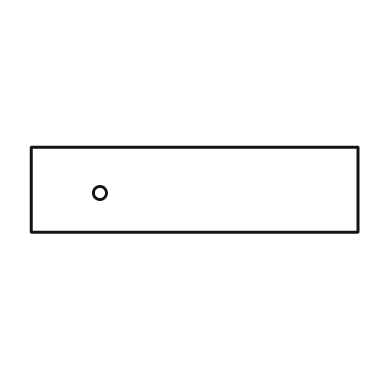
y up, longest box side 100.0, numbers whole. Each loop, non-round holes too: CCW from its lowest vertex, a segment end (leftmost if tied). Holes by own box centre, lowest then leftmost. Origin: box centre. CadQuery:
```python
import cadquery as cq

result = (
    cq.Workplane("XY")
    .moveTo(-50.0, -13.0)
    .lineTo(50.0, -13.0)
    .lineTo(50.0, 13.0)
    .lineTo(-50.0, 13.0)
    .close()
    .moveTo(-29.0, -1.0)
    .circle(2.0)
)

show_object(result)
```